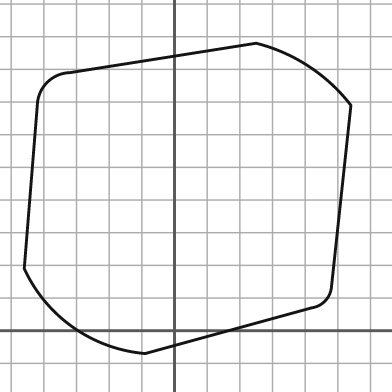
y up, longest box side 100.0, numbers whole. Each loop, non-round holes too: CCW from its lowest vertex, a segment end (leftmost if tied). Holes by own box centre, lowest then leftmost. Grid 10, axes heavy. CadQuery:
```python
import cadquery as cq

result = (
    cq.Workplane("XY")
    .moveTo(-9.0, -7.0)
    .lineTo(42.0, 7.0)
    .threePointArc((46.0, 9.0), (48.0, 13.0))
    .lineTo(54.0, 69.0)
    .threePointArc((41.0, 81.0), (25.0, 88.0))
    .lineTo(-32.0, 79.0)
    .threePointArc((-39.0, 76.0), (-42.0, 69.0))
    .lineTo(-46.0, 19.0)
    .threePointArc((-31.0, 1.0), (-9.0, -7.0))
    .close()
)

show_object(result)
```